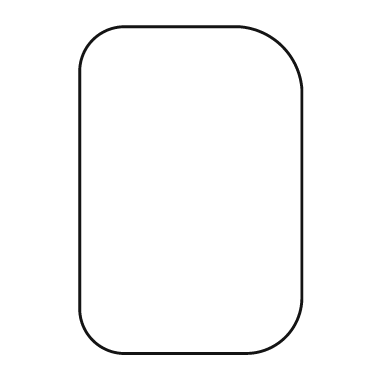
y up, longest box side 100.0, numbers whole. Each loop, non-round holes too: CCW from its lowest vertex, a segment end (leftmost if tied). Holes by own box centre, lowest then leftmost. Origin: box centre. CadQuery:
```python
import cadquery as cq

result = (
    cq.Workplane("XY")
    .moveTo(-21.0, -50.0)
    .lineTo(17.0, -50.0)
    .threePointArc((29.0, -45.0), (34.0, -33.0))
    .lineTo(34.0, 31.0)
    .threePointArc((28.0, 44.0), (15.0, 50.0))
    .lineTo(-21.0, 50.0)
    .threePointArc((-30.0, 46.0), (-34.0, 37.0))
    .lineTo(-34.0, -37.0)
    .threePointArc((-30.0, -46.0), (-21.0, -50.0))
    .close()
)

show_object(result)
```